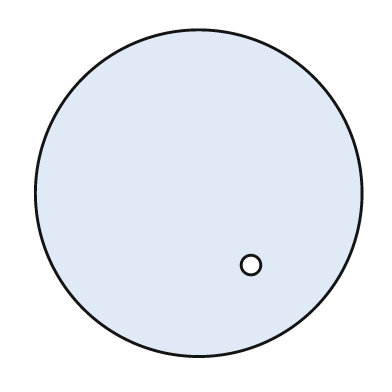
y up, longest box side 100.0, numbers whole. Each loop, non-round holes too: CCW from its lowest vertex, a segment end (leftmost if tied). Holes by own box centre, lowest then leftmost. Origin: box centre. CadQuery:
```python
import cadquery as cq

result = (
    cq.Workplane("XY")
    .moveTo(0.0, 0.0)
    .circle(50.0)
    .moveTo(16.0, -22.0)
    .circle(3.0)
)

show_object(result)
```